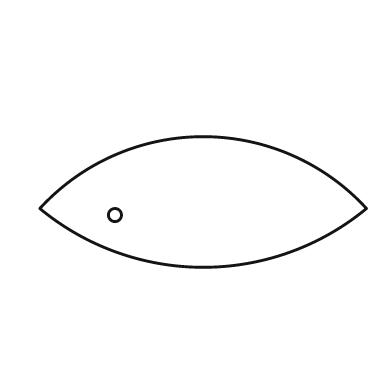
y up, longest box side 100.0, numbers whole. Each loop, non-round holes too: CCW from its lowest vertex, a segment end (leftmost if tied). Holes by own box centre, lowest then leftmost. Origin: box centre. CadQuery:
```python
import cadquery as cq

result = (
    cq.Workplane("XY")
    .moveTo(-50.0, -2.0)
    .threePointArc((0.0, -20.0), (50.0, -2.0))
    .threePointArc((0.0, 20.0), (-50.0, -2.0))
    .close()
    .moveTo(-27.0, -4.0)
    .circle(2.0)
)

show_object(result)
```